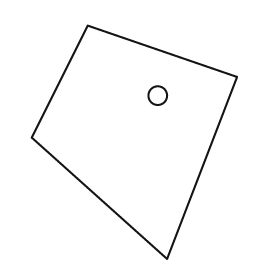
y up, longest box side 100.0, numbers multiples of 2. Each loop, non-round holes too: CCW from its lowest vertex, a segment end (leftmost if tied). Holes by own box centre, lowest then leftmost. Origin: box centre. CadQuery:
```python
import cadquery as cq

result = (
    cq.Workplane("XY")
    .moveTo(14.0, -50.0)
    .lineTo(44.0, 28.0)
    .lineTo(-20.0, 50.0)
    .lineTo(-44.0, 2.0)
    .close()
    .moveTo(10.0, 20.0)
    .circle(4.0)
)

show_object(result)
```